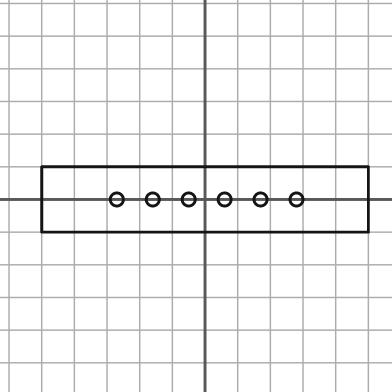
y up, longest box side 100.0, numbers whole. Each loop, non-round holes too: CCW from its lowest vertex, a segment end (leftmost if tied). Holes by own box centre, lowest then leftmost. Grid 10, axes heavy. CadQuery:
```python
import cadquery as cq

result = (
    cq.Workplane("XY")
    .moveTo(-50.0, -10.0)
    .lineTo(50.0, -10.0)
    .lineTo(50.0, 10.0)
    .lineTo(-50.0, 10.0)
    .close()
    .moveTo(-27.0, 0.0)
    .circle(2.0)
    .moveTo(-16.0, 0.0)
    .circle(2.0)
    .moveTo(-5.0, 0.0)
    .circle(2.0)
    .moveTo(6.0, 0.0)
    .circle(2.0)
    .moveTo(17.0, 0.0)
    .circle(2.0)
    .moveTo(28.0, 0.0)
    .circle(2.0)
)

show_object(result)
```